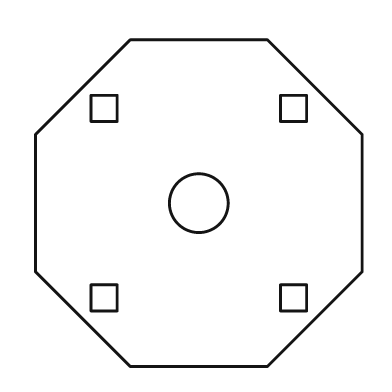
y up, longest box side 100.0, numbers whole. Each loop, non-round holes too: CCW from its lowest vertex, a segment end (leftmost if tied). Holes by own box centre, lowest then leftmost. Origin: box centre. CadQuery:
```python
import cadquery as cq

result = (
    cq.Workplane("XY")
    .moveTo(-21.0, -50.0)
    .lineTo(21.0, -50.0)
    .lineTo(50.0, -21.0)
    .lineTo(50.0, 21.0)
    .lineTo(21.0, 50.0)
    .lineTo(-21.0, 50.0)
    .lineTo(-50.0, 21.0)
    .lineTo(-50.0, -21.0)
    .close()
    .moveTo(-33.0, -33.0)
    .lineTo(-25.0, -33.0)
    .lineTo(-25.0, -25.0)
    .lineTo(-33.0, -25.0)
    .close()
    .moveTo(25.0, -33.0)
    .lineTo(33.0, -33.0)
    .lineTo(33.0, -25.0)
    .lineTo(25.0, -25.0)
    .close()
    .moveTo(0.0, 0.0)
    .circle(9.0)
    .moveTo(-33.0, 25.0)
    .lineTo(-25.0, 25.0)
    .lineTo(-25.0, 33.0)
    .lineTo(-33.0, 33.0)
    .close()
    .moveTo(25.0, 25.0)
    .lineTo(33.0, 25.0)
    .lineTo(33.0, 33.0)
    .lineTo(25.0, 33.0)
    .close()
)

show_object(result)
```